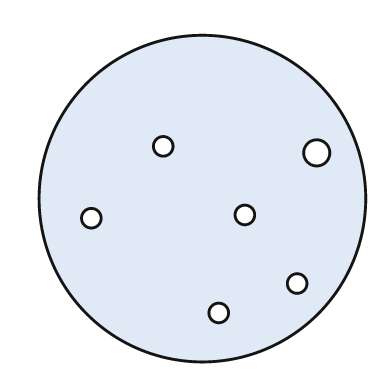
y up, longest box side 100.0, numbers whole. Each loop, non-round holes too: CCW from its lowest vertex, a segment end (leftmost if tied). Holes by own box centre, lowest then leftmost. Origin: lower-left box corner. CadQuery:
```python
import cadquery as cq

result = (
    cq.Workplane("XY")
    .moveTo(50.0, 50.0)
    .circle(50.0)
    .moveTo(55.0, 15.0)
    .circle(3.0)
    .moveTo(79.0, 24.0)
    .circle(3.0)
    .moveTo(16.0, 44.0)
    .circle(3.0)
    .moveTo(63.0, 45.0)
    .circle(3.0)
    .moveTo(85.0, 64.0)
    .circle(4.0)
    .moveTo(38.0, 66.0)
    .circle(3.0)
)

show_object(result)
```